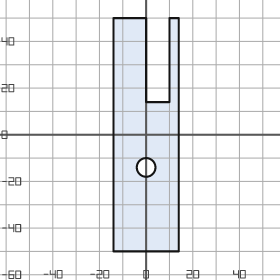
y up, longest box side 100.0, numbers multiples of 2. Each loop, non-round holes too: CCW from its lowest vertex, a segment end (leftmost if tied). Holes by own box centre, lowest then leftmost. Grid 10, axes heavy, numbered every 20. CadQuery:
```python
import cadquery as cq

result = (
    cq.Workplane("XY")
    .moveTo(-14.0, -50.0)
    .lineTo(14.0, -50.0)
    .lineTo(14.0, 50.0)
    .lineTo(10.0, 50.0)
    .lineTo(10.0, 14.0)
    .lineTo(0.0, 14.0)
    .lineTo(0.0, 50.0)
    .lineTo(-14.0, 50.0)
    .close()
    .moveTo(0.0, -14.0)
    .circle(4.0)
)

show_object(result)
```